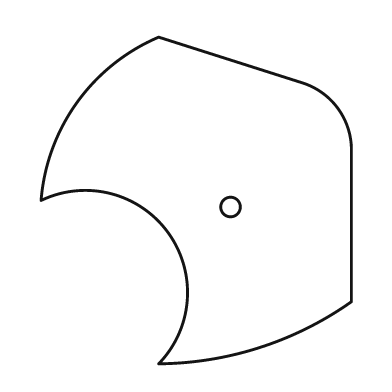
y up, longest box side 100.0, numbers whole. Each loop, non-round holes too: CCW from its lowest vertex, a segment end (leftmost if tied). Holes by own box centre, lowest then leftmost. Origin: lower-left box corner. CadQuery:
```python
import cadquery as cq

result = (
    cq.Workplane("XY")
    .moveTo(36.0, 0.0)
    .threePointArc((67.0, 5.0), (95.0, 19.0))
    .lineTo(95.0, 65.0)
    .threePointArc((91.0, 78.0), (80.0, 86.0))
    .lineTo(36.0, 100.0)
    .threePointArc((11.0, 80.0), (0.0, 50.0))
    .threePointArc((39.0, 40.0), (36.0, 0.0))
    .close()
    .moveTo(58.0, 48.0)
    .circle(3.0)
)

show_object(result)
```